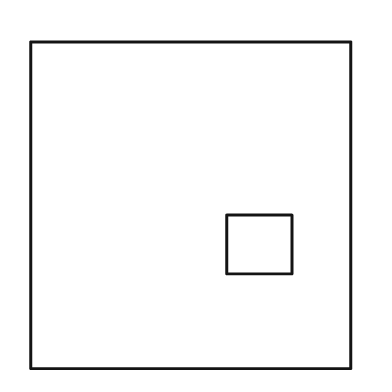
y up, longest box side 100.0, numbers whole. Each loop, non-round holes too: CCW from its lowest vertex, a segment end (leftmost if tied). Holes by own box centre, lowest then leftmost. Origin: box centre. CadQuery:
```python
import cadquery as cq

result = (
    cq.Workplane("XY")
    .moveTo(-49.0, -50.0)
    .lineTo(49.0, -50.0)
    .lineTo(49.0, 50.0)
    .lineTo(-49.0, 50.0)
    .close()
    .moveTo(11.0, -21.0)
    .lineTo(31.0, -21.0)
    .lineTo(31.0, -3.0)
    .lineTo(11.0, -3.0)
    .close()
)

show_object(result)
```